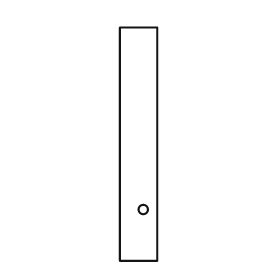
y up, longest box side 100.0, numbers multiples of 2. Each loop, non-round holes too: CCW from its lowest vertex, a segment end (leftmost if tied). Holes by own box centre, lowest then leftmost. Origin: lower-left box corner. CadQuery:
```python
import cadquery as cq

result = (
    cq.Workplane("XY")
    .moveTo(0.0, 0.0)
    .lineTo(16.0, 0.0)
    .lineTo(16.0, 100.0)
    .lineTo(0.0, 100.0)
    .close()
    .moveTo(10.0, 22.0)
    .circle(2.0)
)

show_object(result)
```